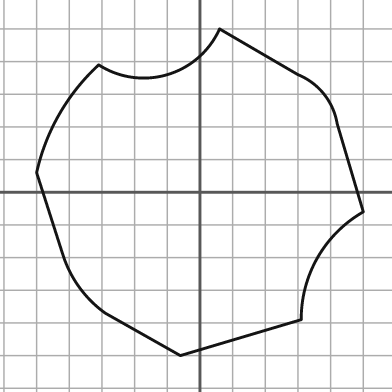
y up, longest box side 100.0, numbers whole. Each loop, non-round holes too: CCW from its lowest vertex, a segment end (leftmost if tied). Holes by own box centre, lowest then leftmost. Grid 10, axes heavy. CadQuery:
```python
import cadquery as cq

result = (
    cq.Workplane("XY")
    .moveTo(-6.0, -50.0)
    .lineTo(31.0, -39.0)
    .threePointArc((36.0, -20.0), (50.0, -6.0))
    .lineTo(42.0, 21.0)
    .threePointArc((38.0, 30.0), (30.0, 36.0))
    .lineTo(6.0, 50.0)
    .threePointArc((-10.0, 36.0), (-31.0, 39.0))
    .threePointArc((-43.0, 24.0), (-50.0, 6.0))
    .lineTo(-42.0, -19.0)
    .threePointArc((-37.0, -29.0), (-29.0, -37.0))
    .close()
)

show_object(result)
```